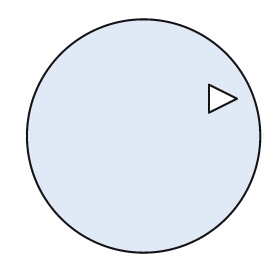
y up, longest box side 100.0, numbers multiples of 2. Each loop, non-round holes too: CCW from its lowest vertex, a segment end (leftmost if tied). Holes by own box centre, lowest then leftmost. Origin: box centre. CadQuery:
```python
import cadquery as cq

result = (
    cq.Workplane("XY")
    .moveTo(0.0, 0.0)
    .circle(50.0)
    .moveTo(28.0, 10.0)
    .lineTo(40.0, 16.0)
    .lineTo(28.0, 22.0)
    .close()
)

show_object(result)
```